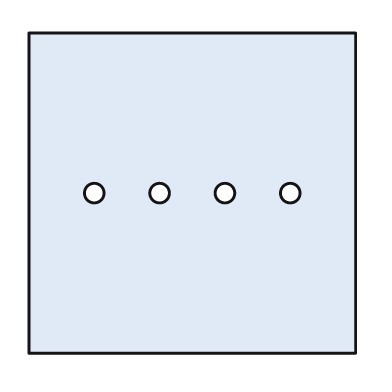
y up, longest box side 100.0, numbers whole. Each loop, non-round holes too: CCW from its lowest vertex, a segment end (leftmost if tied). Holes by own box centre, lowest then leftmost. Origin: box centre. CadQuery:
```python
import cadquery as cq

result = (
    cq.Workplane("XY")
    .moveTo(-50.0, -49.0)
    .lineTo(50.0, -49.0)
    .lineTo(50.0, 49.0)
    .lineTo(-50.0, 49.0)
    .close()
    .moveTo(-30.0, 0.0)
    .circle(3.0)
    .moveTo(-10.0, 0.0)
    .circle(3.0)
    .moveTo(10.0, 0.0)
    .circle(3.0)
    .moveTo(30.0, 0.0)
    .circle(3.0)
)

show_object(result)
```